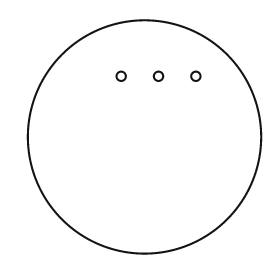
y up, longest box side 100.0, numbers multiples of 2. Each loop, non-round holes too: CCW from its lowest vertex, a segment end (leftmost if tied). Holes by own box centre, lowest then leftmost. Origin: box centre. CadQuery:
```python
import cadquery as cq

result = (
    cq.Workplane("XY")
    .moveTo(0.0, 0.0)
    .circle(50.0)
    .moveTo(-10.0, 26.0)
    .circle(2.0)
    .moveTo(6.0, 26.0)
    .circle(2.0)
    .moveTo(22.0, 26.0)
    .circle(2.0)
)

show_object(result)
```